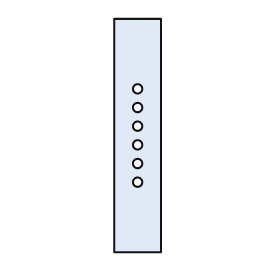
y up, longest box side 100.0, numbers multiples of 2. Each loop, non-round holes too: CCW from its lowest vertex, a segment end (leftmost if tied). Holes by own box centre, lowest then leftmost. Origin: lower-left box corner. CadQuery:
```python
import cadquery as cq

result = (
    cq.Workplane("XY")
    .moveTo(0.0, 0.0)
    .lineTo(20.0, 0.0)
    .lineTo(20.0, 100.0)
    .lineTo(0.0, 100.0)
    .close()
    .moveTo(10.0, 30.0)
    .circle(2.0)
    .moveTo(10.0, 38.0)
    .circle(2.0)
    .moveTo(10.0, 46.0)
    .circle(2.0)
    .moveTo(10.0, 54.0)
    .circle(2.0)
    .moveTo(10.0, 62.0)
    .circle(2.0)
    .moveTo(10.0, 70.0)
    .circle(2.0)
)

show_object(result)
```